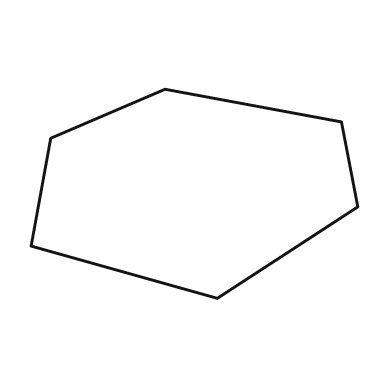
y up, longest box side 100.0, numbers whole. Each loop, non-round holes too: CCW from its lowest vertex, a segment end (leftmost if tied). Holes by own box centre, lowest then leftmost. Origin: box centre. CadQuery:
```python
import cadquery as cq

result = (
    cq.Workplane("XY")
    .moveTo(7.0, -32.0)
    .lineTo(50.0, -4.0)
    .lineTo(45.0, 22.0)
    .lineTo(-9.0, 32.0)
    .lineTo(-44.0, 17.0)
    .lineTo(-50.0, -16.0)
    .close()
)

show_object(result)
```